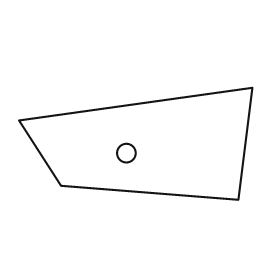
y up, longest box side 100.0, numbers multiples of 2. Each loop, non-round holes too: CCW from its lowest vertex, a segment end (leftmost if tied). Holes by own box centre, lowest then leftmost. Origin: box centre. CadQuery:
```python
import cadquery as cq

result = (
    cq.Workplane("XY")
    .moveTo(44.0, -24.0)
    .lineTo(50.0, 24.0)
    .lineTo(-50.0, 10.0)
    .lineTo(-32.0, -18.0)
    .close()
    .moveTo(-4.0, -4.0)
    .circle(4.0)
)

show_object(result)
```